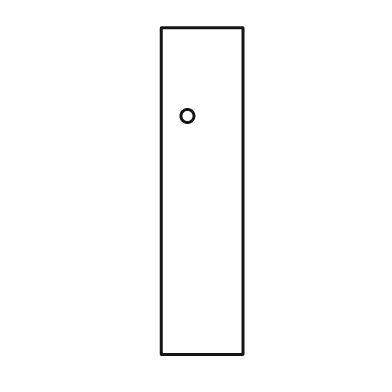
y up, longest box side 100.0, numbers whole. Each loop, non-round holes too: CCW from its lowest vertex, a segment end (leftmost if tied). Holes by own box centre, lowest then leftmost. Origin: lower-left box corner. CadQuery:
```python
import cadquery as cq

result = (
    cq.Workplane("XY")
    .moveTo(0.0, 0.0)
    .lineTo(25.0, 0.0)
    .lineTo(25.0, 100.0)
    .lineTo(0.0, 100.0)
    .close()
    .moveTo(8.0, 73.0)
    .circle(2.0)
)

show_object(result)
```